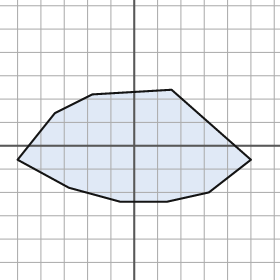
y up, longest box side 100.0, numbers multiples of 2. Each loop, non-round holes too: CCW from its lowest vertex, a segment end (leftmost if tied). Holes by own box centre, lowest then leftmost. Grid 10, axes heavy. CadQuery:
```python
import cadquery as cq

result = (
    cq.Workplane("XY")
    .moveTo(-6.0, -24.0)
    .lineTo(14.0, -24.0)
    .lineTo(32.0, -20.0)
    .lineTo(50.0, -6.0)
    .lineTo(16.0, 24.0)
    .lineTo(-18.0, 22.0)
    .lineTo(-34.0, 14.0)
    .lineTo(-50.0, -6.0)
    .lineTo(-28.0, -18.0)
    .close()
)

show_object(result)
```